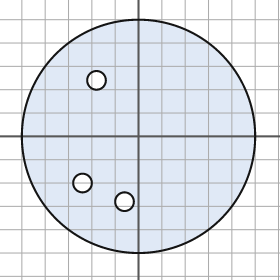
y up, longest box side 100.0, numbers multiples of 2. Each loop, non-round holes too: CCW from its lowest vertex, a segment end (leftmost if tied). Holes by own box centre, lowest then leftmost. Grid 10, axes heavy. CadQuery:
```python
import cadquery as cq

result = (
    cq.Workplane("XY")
    .moveTo(0.0, 0.0)
    .circle(50.0)
    .moveTo(-6.0, -28.0)
    .circle(4.0)
    .moveTo(-24.0, -20.0)
    .circle(4.0)
    .moveTo(-18.0, 24.0)
    .circle(4.0)
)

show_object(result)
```